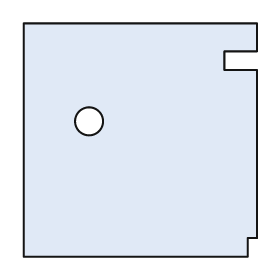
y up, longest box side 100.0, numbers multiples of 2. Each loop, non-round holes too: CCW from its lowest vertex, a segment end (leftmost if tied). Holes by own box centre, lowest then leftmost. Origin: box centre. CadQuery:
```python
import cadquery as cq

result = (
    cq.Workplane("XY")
    .moveTo(-50.0, -50.0)
    .lineTo(46.0, -50.0)
    .lineTo(46.0, -42.0)
    .lineTo(50.0, -42.0)
    .lineTo(50.0, 30.0)
    .lineTo(36.0, 30.0)
    .lineTo(36.0, 38.0)
    .lineTo(50.0, 38.0)
    .lineTo(50.0, 50.0)
    .lineTo(-50.0, 50.0)
    .close()
    .moveTo(-22.0, 8.0)
    .circle(6.0)
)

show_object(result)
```